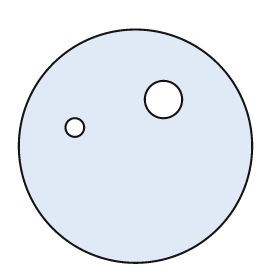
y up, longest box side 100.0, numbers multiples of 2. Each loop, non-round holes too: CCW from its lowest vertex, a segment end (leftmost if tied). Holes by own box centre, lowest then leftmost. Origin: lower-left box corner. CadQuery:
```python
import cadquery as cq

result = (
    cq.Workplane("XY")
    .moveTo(50.0, 50.0)
    .circle(50.0)
    .moveTo(24.0, 58.0)
    .circle(4.0)
    .moveTo(62.0, 70.0)
    .circle(8.0)
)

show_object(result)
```